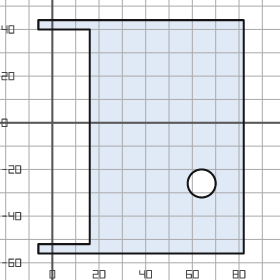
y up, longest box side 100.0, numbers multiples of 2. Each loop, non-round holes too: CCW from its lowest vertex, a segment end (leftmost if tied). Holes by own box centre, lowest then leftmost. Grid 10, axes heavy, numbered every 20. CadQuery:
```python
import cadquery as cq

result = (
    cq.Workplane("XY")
    .moveTo(-6.0, -56.0)
    .lineTo(82.0, -56.0)
    .lineTo(82.0, 44.0)
    .lineTo(-6.0, 44.0)
    .lineTo(-6.0, 40.0)
    .lineTo(16.0, 40.0)
    .lineTo(16.0, -52.0)
    .lineTo(-6.0, -52.0)
    .close()
    .moveTo(64.0, -26.0)
    .circle(6.0)
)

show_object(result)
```